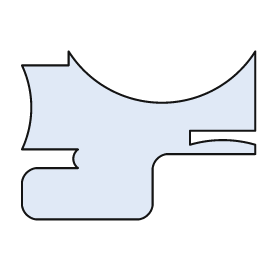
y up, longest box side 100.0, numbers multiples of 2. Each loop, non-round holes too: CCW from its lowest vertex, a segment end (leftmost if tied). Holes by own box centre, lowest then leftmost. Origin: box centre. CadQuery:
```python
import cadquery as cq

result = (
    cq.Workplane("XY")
    .moveTo(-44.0, -36.0)
    .lineTo(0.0, -36.0)
    .threePointArc((4.0, -34.0), (6.0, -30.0))
    .lineTo(6.0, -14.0)
    .threePointArc((8.0, -10.0), (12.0, -8.0))
    .lineTo(50.0, -8.0)
    .lineTo(50.0, -4.0)
    .threePointArc((36.0, -2.0), (22.0, -4.0))
    .lineTo(22.0, 2.0)
    .lineTo(50.0, 2.0)
    .lineTo(50.0, 36.0)
    .threePointArc((10.0, 14.0), (-30.0, 36.0))
    .lineTo(-30.0, 30.0)
    .lineTo(-50.0, 30.0)
    .threePointArc((-46.0, 12.0), (-50.0, -6.0))
    .lineTo(-26.0, -6.0)
    .threePointArc((-28.0, -10.0), (-26.0, -14.0))
    .lineTo(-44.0, -14.0)
    .threePointArc((-48.0, -16.0), (-50.0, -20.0))
    .lineTo(-50.0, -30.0)
    .threePointArc((-48.0, -34.0), (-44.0, -36.0))
    .close()
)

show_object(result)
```